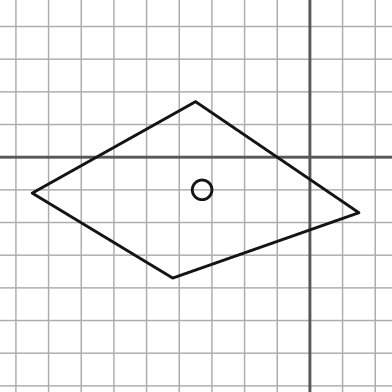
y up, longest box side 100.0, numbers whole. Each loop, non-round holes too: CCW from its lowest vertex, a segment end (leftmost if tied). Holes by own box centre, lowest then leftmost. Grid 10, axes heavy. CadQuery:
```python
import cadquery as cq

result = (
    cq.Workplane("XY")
    .moveTo(-42.0, -37.0)
    .lineTo(15.0, -17.0)
    .lineTo(-35.0, 17.0)
    .lineTo(-85.0, -11.0)
    .close()
    .moveTo(-33.0, -10.0)
    .circle(3.0)
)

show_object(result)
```